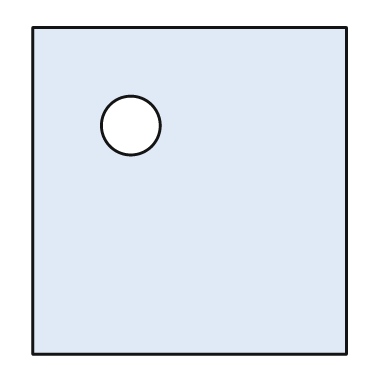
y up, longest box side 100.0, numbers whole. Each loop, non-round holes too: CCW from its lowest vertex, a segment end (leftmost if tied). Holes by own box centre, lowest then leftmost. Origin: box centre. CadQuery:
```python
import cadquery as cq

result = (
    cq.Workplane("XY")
    .moveTo(-48.0, -50.0)
    .lineTo(48.0, -50.0)
    .lineTo(48.0, 50.0)
    .lineTo(-48.0, 50.0)
    .close()
    .moveTo(-18.0, 20.0)
    .circle(9.0)
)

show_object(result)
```